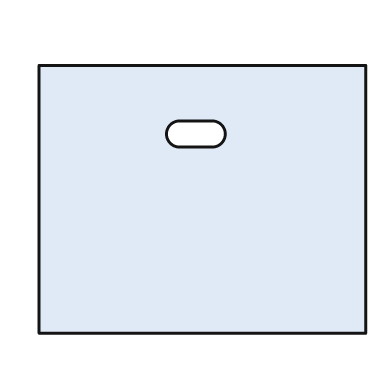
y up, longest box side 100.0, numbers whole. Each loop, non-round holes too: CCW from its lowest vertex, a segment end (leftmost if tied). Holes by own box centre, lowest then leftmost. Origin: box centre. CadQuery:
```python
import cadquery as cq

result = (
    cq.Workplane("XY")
    .moveTo(-50.0, -41.0)
    .lineTo(50.0, -41.0)
    .lineTo(50.0, 41.0)
    .lineTo(-50.0, 41.0)
    .close()
    .moveTo(-7.0, 16.0)
    .lineTo(3.0, 16.0)
    .threePointArc((7.0, 20.0), (3.0, 24.0))
    .lineTo(-7.0, 24.0)
    .threePointArc((-11.0, 20.0), (-7.0, 16.0))
    .close()
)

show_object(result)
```